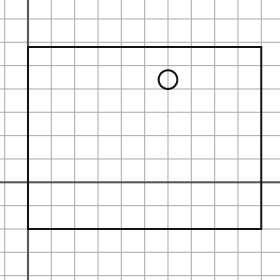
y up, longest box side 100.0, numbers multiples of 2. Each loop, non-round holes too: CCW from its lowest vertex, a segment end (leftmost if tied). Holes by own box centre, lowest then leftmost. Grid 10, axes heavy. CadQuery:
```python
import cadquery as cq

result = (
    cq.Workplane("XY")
    .moveTo(0.0, -20.0)
    .lineTo(100.0, -20.0)
    .lineTo(100.0, 58.0)
    .lineTo(0.0, 58.0)
    .close()
    .moveTo(60.0, 44.0)
    .circle(4.0)
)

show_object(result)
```